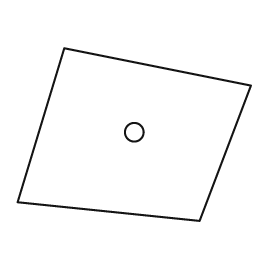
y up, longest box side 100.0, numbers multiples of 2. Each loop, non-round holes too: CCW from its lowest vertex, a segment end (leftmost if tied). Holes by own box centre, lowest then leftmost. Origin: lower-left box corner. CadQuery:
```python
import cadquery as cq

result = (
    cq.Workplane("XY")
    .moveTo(78.0, 0.0)
    .lineTo(100.0, 58.0)
    .lineTo(20.0, 74.0)
    .lineTo(0.0, 8.0)
    .close()
    .moveTo(50.0, 38.0)
    .circle(4.0)
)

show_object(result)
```